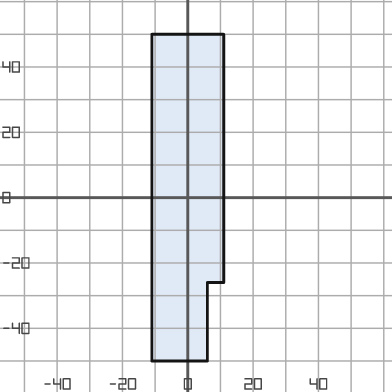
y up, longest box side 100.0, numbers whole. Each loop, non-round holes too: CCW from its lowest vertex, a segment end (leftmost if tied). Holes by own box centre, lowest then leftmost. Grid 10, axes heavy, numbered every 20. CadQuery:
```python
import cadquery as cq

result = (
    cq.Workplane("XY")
    .moveTo(-11.0, -50.0)
    .lineTo(6.0, -50.0)
    .lineTo(6.0, -26.0)
    .lineTo(11.0, -26.0)
    .lineTo(11.0, 50.0)
    .lineTo(-11.0, 50.0)
    .close()
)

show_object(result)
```